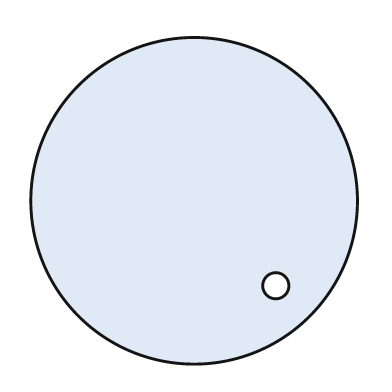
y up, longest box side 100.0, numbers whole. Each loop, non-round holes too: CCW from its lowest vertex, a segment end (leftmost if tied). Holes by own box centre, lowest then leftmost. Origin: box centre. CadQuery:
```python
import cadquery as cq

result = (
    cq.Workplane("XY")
    .moveTo(0.0, 0.0)
    .circle(50.0)
    .moveTo(25.0, -26.0)
    .circle(4.0)
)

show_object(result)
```